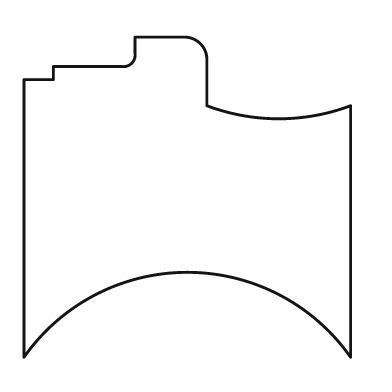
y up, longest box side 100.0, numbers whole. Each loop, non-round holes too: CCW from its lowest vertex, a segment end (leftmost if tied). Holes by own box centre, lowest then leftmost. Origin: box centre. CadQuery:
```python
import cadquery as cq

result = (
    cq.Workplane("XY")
    .moveTo(-50.0, -49.0)
    .threePointArc((0.0, -23.0), (50.0, -49.0))
    .lineTo(50.0, 28.0)
    .threePointArc((28.0, 24.0), (6.0, 28.0))
    .lineTo(6.0, 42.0)
    .threePointArc((4.0, 47.0), (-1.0, 49.0))
    .lineTo(-16.0, 49.0)
    .lineTo(-16.0, 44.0)
    .threePointArc((-17.0, 41.0), (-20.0, 40.0))
    .lineTo(-41.0, 40.0)
    .lineTo(-41.0, 36.0)
    .lineTo(-50.0, 36.0)
    .close()
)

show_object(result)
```